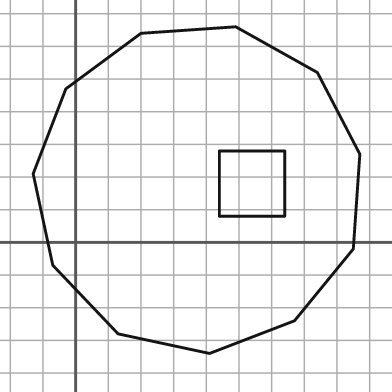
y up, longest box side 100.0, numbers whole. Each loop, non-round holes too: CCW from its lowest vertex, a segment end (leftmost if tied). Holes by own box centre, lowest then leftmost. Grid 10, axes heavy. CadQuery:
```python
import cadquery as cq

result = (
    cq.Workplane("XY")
    .moveTo(41.0, -34.0)
    .lineTo(67.0, -24.0)
    .lineTo(85.0, -2.0)
    .lineTo(87.0, 27.0)
    .lineTo(74.0, 52.0)
    .lineTo(49.0, 66.0)
    .lineTo(20.0, 64.0)
    .lineTo(-3.0, 47.0)
    .lineTo(-13.0, 21.0)
    .lineTo(-7.0, -7.0)
    .lineTo(13.0, -28.0)
    .close()
    .moveTo(44.0, 8.0)
    .lineTo(64.0, 8.0)
    .lineTo(64.0, 28.0)
    .lineTo(44.0, 28.0)
    .close()
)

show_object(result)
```